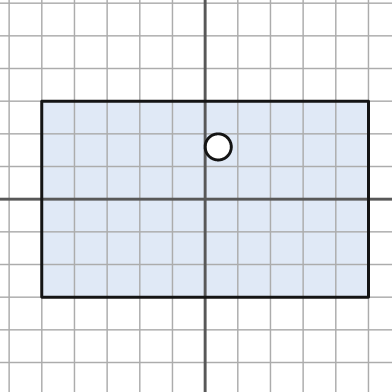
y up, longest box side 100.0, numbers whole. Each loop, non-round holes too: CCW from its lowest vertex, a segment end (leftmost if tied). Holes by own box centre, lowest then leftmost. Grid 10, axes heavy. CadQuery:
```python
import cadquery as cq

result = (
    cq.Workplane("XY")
    .moveTo(-50.0, -30.0)
    .lineTo(50.0, -30.0)
    .lineTo(50.0, 30.0)
    .lineTo(-50.0, 30.0)
    .close()
    .moveTo(4.0, 16.0)
    .circle(4.0)
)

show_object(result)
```